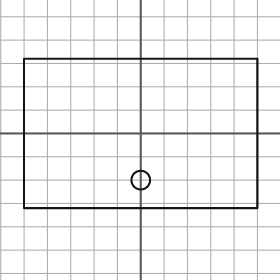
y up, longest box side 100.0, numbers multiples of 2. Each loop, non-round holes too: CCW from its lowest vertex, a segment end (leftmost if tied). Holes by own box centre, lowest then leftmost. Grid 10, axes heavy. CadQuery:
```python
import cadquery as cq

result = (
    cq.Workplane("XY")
    .moveTo(-50.0, -32.0)
    .lineTo(50.0, -32.0)
    .lineTo(50.0, 32.0)
    .lineTo(-50.0, 32.0)
    .close()
    .moveTo(0.0, -20.0)
    .circle(4.0)
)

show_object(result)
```